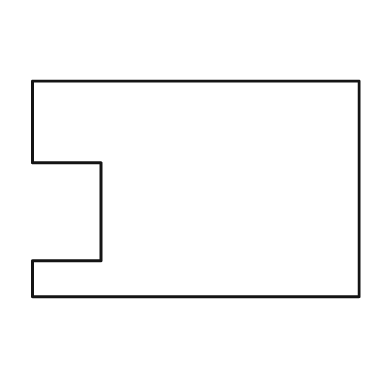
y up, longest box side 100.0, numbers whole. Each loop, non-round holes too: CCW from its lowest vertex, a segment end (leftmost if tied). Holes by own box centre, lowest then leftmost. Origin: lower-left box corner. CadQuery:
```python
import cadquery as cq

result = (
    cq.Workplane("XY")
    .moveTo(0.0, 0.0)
    .lineTo(100.0, 0.0)
    .lineTo(100.0, 66.0)
    .lineTo(0.0, 66.0)
    .lineTo(0.0, 41.0)
    .lineTo(21.0, 41.0)
    .lineTo(21.0, 11.0)
    .lineTo(0.0, 11.0)
    .close()
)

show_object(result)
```